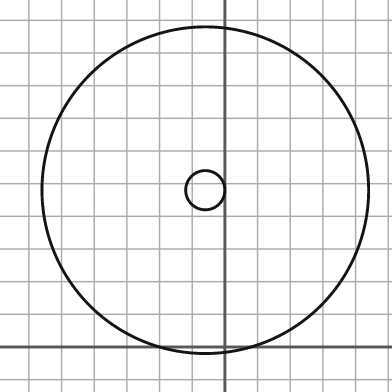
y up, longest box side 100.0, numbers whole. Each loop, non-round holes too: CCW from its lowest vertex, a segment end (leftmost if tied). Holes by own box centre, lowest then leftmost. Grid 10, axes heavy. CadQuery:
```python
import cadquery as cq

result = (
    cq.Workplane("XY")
    .moveTo(-6.0, 48.0)
    .circle(50.0)
    .moveTo(-6.0, 48.0)
    .circle(6.0)
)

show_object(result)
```